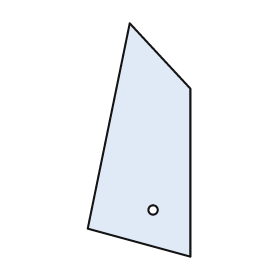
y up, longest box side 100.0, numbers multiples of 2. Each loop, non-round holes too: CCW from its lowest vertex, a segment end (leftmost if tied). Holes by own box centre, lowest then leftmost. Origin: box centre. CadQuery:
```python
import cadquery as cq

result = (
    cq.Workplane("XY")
    .moveTo(22.0, -50.0)
    .lineTo(22.0, 22.0)
    .lineTo(-4.0, 50.0)
    .lineTo(-22.0, -38.0)
    .close()
    .moveTo(6.0, -30.0)
    .circle(2.0)
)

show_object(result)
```